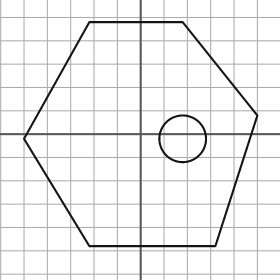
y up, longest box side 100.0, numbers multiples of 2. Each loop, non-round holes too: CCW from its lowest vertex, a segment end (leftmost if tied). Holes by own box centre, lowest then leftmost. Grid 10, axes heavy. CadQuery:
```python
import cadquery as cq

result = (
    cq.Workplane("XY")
    .moveTo(-22.0, -48.0)
    .lineTo(32.0, -48.0)
    .lineTo(50.0, 8.0)
    .lineTo(18.0, 48.0)
    .lineTo(-22.0, 48.0)
    .lineTo(-50.0, -2.0)
    .close()
    .moveTo(18.0, -2.0)
    .circle(10.0)
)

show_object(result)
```